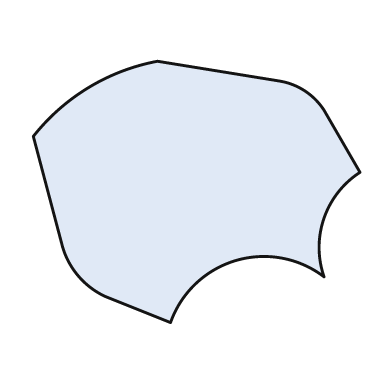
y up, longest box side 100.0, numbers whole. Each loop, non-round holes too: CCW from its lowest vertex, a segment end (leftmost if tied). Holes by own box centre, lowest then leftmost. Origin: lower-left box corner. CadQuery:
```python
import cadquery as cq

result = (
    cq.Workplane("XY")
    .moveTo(42.0, 0.0)
    .threePointArc((62.0, 19.0), (89.0, 14.0))
    .threePointArc((89.0, 32.0), (100.0, 46.0))
    .lineTo(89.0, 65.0)
    .threePointArc((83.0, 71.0), (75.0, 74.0))
    .lineTo(38.0, 80.0)
    .threePointArc((17.0, 72.0), (0.0, 57.0))
    .lineTo(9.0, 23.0)
    .threePointArc((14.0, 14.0), (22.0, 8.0))
    .close()
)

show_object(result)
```